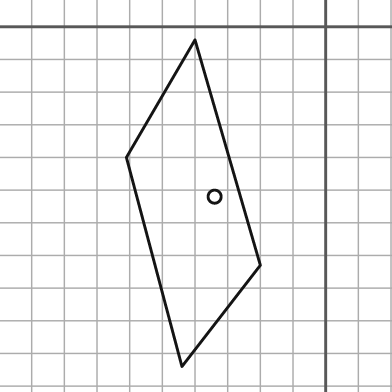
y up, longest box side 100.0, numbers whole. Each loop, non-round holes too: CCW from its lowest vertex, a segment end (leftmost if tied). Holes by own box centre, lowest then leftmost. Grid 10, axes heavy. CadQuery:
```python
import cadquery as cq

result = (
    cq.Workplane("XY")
    .moveTo(-44.0, -104.0)
    .lineTo(-20.0, -73.0)
    .lineTo(-40.0, -4.0)
    .lineTo(-61.0, -40.0)
    .close()
    .moveTo(-34.0, -52.0)
    .circle(2.0)
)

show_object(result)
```